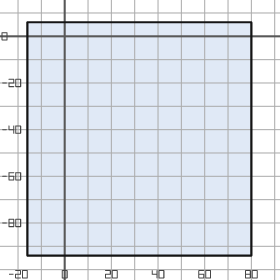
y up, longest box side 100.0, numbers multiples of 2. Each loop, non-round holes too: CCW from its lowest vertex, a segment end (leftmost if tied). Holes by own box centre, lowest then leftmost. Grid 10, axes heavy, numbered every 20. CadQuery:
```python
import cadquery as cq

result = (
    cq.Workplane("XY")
    .moveTo(-16.0, -94.0)
    .lineTo(80.0, -94.0)
    .lineTo(80.0, 6.0)
    .lineTo(-16.0, 6.0)
    .close()
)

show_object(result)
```